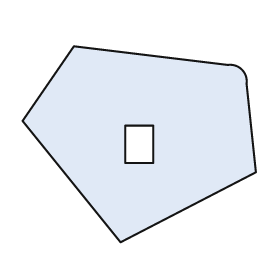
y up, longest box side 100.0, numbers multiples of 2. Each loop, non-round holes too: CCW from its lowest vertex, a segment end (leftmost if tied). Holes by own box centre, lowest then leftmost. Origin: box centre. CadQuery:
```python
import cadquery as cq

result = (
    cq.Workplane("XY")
    .moveTo(-8.0, -42.0)
    .lineTo(50.0, -12.0)
    .lineTo(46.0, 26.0)
    .threePointArc((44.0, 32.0), (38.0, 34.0))
    .lineTo(-28.0, 42.0)
    .lineTo(-50.0, 10.0)
    .close()
    .moveTo(-6.0, -8.0)
    .lineTo(6.0, -8.0)
    .lineTo(6.0, 8.0)
    .lineTo(-6.0, 8.0)
    .close()
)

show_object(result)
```